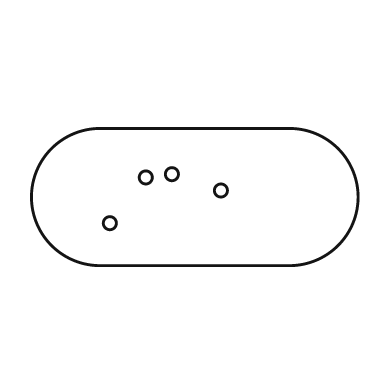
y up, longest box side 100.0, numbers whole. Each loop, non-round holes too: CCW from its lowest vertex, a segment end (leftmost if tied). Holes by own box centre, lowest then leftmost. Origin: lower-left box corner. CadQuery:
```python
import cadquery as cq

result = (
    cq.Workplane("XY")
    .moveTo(21.0, 0.0)
    .lineTo(79.0, 0.0)
    .threePointArc((100.0, 21.0), (79.0, 42.0))
    .lineTo(21.0, 42.0)
    .threePointArc((0.0, 21.0), (21.0, 0.0))
    .close()
    .moveTo(24.0, 13.0)
    .circle(2.0)
    .moveTo(58.0, 23.0)
    .circle(2.0)
    .moveTo(35.0, 27.0)
    .circle(2.0)
    .moveTo(43.0, 28.0)
    .circle(2.0)
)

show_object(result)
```